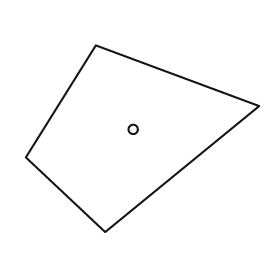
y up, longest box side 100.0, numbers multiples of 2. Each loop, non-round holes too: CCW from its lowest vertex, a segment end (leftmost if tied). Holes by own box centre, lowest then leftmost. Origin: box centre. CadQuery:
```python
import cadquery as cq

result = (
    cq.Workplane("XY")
    .moveTo(-16.0, -40.0)
    .lineTo(50.0, 14.0)
    .lineTo(-20.0, 40.0)
    .lineTo(-50.0, -8.0)
    .close()
    .moveTo(-4.0, 4.0)
    .circle(2.0)
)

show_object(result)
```